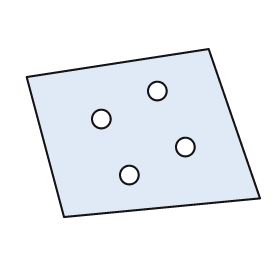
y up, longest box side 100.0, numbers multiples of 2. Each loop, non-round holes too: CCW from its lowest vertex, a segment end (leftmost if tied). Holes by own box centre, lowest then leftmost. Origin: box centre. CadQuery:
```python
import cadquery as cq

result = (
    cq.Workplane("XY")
    .moveTo(-34.0, -36.0)
    .lineTo(50.0, -28.0)
    .lineTo(28.0, 36.0)
    .lineTo(-50.0, 24.0)
    .close()
    .moveTo(-6.0, -18.0)
    .circle(4.0)
    .moveTo(18.0, -6.0)
    .circle(4.0)
    .moveTo(-18.0, 6.0)
    .circle(4.0)
    .moveTo(6.0, 18.0)
    .circle(4.0)
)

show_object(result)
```